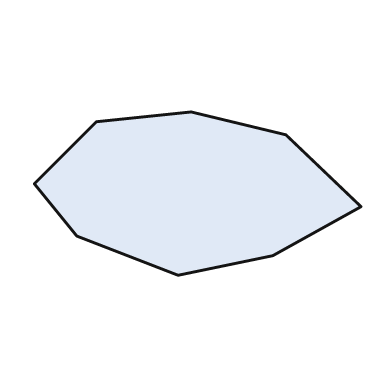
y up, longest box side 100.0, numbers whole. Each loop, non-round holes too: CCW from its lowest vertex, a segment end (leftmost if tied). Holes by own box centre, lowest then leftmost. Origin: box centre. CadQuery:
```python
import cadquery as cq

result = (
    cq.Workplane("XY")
    .moveTo(-6.0, -25.0)
    .lineTo(23.0, -19.0)
    .lineTo(50.0, -4.0)
    .lineTo(27.0, 18.0)
    .lineTo(-2.0, 25.0)
    .lineTo(-31.0, 22.0)
    .lineTo(-50.0, 3.0)
    .lineTo(-37.0, -13.0)
    .close()
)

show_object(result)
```